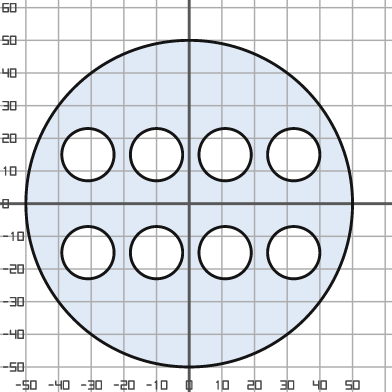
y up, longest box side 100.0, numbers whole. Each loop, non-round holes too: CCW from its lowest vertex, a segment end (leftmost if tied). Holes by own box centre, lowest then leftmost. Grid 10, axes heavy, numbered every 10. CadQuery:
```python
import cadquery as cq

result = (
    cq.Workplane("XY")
    .moveTo(0.0, 0.0)
    .circle(50.0)
    .moveTo(-31.0, -15.0)
    .circle(8.0)
    .moveTo(-10.0, -15.0)
    .circle(8.0)
    .moveTo(11.0, -15.0)
    .circle(8.0)
    .moveTo(32.0, -15.0)
    .circle(8.0)
    .moveTo(-31.0, 15.0)
    .circle(8.0)
    .moveTo(-10.0, 15.0)
    .circle(8.0)
    .moveTo(11.0, 15.0)
    .circle(8.0)
    .moveTo(32.0, 15.0)
    .circle(8.0)
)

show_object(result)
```